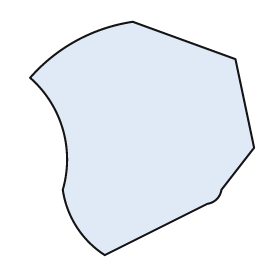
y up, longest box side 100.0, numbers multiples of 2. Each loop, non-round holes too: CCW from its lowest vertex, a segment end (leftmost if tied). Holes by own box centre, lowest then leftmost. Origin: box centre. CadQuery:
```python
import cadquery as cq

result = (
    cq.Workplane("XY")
    .moveTo(-16.0, -50.0)
    .lineTo(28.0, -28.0)
    .threePointArc((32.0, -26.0), (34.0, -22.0))
    .lineTo(48.0, -4.0)
    .lineTo(40.0, 34.0)
    .lineTo(-4.0, 50.0)
    .threePointArc((-28.0, 42.0), (-48.0, 26.0))
    .threePointArc((-34.0, 4.0), (-34.0, -22.0))
    .threePointArc((-28.0, -38.0), (-16.0, -50.0))
    .close()
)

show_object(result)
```